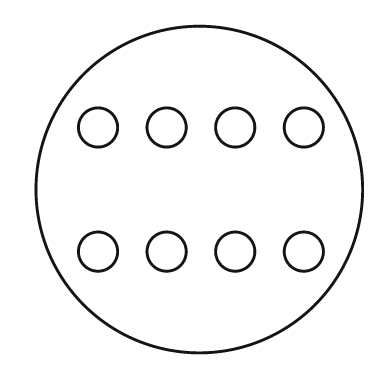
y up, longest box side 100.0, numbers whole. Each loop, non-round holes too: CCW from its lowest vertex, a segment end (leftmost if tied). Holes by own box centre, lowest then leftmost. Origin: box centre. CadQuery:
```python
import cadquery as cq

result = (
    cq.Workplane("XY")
    .moveTo(0.0, 0.0)
    .circle(50.0)
    .moveTo(-31.0, -19.0)
    .circle(6.0)
    .moveTo(-10.0, -19.0)
    .circle(6.0)
    .moveTo(11.0, -19.0)
    .circle(6.0)
    .moveTo(32.0, -19.0)
    .circle(6.0)
    .moveTo(-31.0, 19.0)
    .circle(6.0)
    .moveTo(-10.0, 19.0)
    .circle(6.0)
    .moveTo(11.0, 19.0)
    .circle(6.0)
    .moveTo(32.0, 19.0)
    .circle(6.0)
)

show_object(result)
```